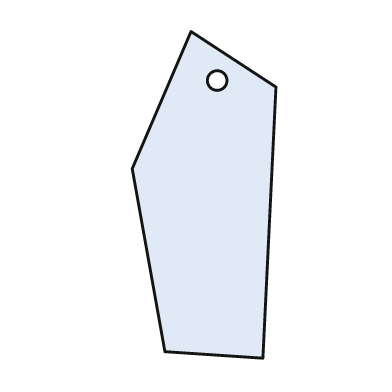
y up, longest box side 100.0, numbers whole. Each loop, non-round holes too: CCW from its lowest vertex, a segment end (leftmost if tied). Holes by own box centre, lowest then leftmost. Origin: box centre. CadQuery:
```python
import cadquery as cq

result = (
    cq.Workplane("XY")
    .moveTo(18.0, -50.0)
    .lineTo(22.0, 33.0)
    .lineTo(-4.0, 50.0)
    .lineTo(-22.0, 8.0)
    .lineTo(-12.0, -48.0)
    .close()
    .moveTo(4.0, 35.0)
    .circle(3.0)
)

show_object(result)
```